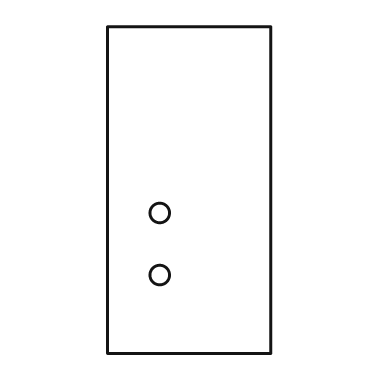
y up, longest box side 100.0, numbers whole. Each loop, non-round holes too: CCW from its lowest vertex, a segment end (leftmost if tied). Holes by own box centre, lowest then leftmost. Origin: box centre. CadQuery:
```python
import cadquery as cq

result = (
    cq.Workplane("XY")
    .moveTo(-25.0, -50.0)
    .lineTo(25.0, -50.0)
    .lineTo(25.0, 50.0)
    .lineTo(-25.0, 50.0)
    .close()
    .moveTo(-9.0, -26.0)
    .circle(3.0)
    .moveTo(-9.0, -7.0)
    .circle(3.0)
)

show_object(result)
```